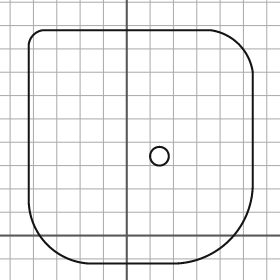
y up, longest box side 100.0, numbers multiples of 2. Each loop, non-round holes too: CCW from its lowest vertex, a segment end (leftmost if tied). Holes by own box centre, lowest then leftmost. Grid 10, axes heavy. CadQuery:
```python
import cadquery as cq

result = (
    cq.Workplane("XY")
    .moveTo(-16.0, -12.0)
    .lineTo(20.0, -12.0)
    .threePointArc((44.0, -2.0), (54.0, 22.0))
    .lineTo(54.0, 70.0)
    .threePointArc((48.0, 82.0), (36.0, 88.0))
    .lineTo(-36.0, 88.0)
    .threePointArc((-40.0, 86.0), (-42.0, 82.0))
    .lineTo(-42.0, 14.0)
    .threePointArc((-34.0, -4.0), (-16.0, -12.0))
    .close()
    .moveTo(14.0, 34.0)
    .circle(4.0)
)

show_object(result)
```